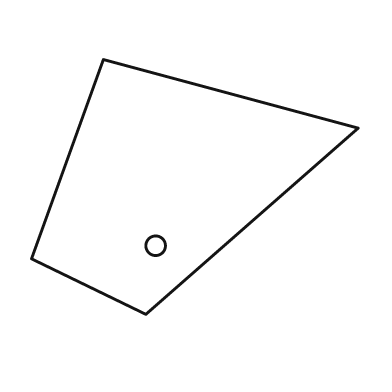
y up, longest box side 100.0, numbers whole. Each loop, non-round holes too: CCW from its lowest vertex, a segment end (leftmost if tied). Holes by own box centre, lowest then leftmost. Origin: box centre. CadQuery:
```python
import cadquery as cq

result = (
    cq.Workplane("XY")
    .moveTo(-15.0, -39.0)
    .lineTo(50.0, 18.0)
    .lineTo(-28.0, 39.0)
    .lineTo(-50.0, -22.0)
    .close()
    .moveTo(-12.0, -18.0)
    .circle(3.0)
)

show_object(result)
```